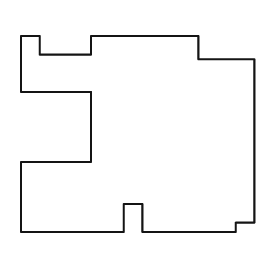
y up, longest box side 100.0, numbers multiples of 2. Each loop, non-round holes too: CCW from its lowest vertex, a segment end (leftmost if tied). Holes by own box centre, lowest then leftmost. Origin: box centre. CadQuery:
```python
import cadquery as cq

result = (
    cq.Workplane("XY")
    .moveTo(-50.0, -42.0)
    .lineTo(-6.0, -42.0)
    .lineTo(-6.0, -30.0)
    .lineTo(2.0, -30.0)
    .lineTo(2.0, -42.0)
    .lineTo(42.0, -42.0)
    .lineTo(42.0, -38.0)
    .lineTo(50.0, -38.0)
    .lineTo(50.0, 32.0)
    .lineTo(26.0, 32.0)
    .lineTo(26.0, 42.0)
    .lineTo(-20.0, 42.0)
    .lineTo(-20.0, 34.0)
    .lineTo(-42.0, 34.0)
    .lineTo(-42.0, 42.0)
    .lineTo(-50.0, 42.0)
    .lineTo(-50.0, 18.0)
    .lineTo(-20.0, 18.0)
    .lineTo(-20.0, -12.0)
    .lineTo(-50.0, -12.0)
    .close()
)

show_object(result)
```